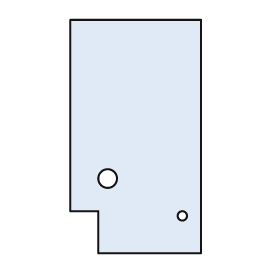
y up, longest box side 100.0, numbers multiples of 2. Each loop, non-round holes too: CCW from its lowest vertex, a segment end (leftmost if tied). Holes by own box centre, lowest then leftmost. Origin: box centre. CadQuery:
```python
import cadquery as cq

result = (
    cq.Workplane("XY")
    .moveTo(-16.0, -50.0)
    .lineTo(28.0, -50.0)
    .lineTo(28.0, 50.0)
    .lineTo(-28.0, 50.0)
    .lineTo(-28.0, -32.0)
    .lineTo(-16.0, -32.0)
    .close()
    .moveTo(20.0, -34.0)
    .circle(2.0)
    .moveTo(-12.0, -18.0)
    .circle(4.0)
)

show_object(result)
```